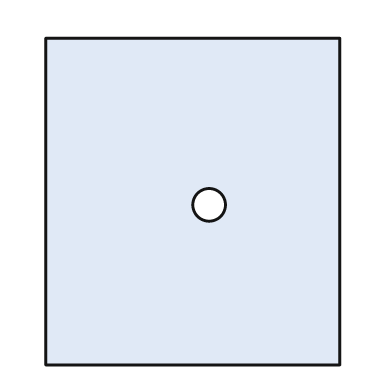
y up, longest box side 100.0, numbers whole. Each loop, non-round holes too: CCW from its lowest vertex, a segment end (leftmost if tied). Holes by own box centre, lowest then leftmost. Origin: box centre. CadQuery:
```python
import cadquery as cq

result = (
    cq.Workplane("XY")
    .moveTo(-45.0, -50.0)
    .lineTo(45.0, -50.0)
    .lineTo(45.0, 50.0)
    .lineTo(-45.0, 50.0)
    .close()
    .moveTo(5.0, -1.0)
    .circle(5.0)
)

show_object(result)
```